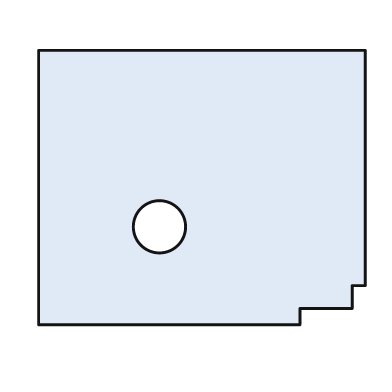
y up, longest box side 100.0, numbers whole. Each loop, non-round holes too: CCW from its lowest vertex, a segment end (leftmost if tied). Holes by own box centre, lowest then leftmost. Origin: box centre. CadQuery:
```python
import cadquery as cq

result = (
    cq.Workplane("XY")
    .moveTo(-50.0, -42.0)
    .lineTo(30.0, -42.0)
    .lineTo(30.0, -37.0)
    .lineTo(46.0, -37.0)
    .lineTo(46.0, -30.0)
    .lineTo(50.0, -30.0)
    .lineTo(50.0, 42.0)
    .lineTo(-50.0, 42.0)
    .close()
    .moveTo(-13.0, -12.0)
    .circle(8.0)
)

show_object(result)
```